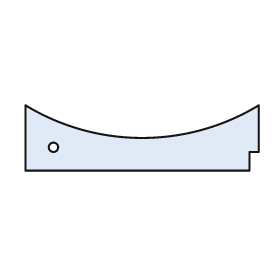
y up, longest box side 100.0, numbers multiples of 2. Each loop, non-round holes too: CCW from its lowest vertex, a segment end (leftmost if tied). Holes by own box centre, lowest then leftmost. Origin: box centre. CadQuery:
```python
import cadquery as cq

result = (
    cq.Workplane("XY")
    .moveTo(-50.0, -14.0)
    .lineTo(46.0, -14.0)
    .lineTo(46.0, -6.0)
    .lineTo(50.0, -6.0)
    .lineTo(50.0, 14.0)
    .threePointArc((0.0, 0.0), (-50.0, 14.0))
    .close()
    .moveTo(-38.0, -4.0)
    .circle(2.0)
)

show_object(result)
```